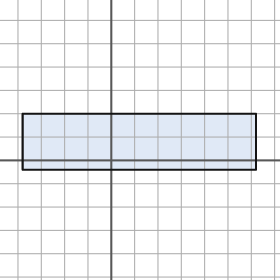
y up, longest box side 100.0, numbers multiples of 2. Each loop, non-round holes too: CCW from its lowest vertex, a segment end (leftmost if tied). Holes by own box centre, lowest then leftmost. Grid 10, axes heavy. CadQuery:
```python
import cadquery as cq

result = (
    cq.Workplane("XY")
    .moveTo(-38.0, -4.0)
    .lineTo(62.0, -4.0)
    .lineTo(62.0, 20.0)
    .lineTo(-38.0, 20.0)
    .close()
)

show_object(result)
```